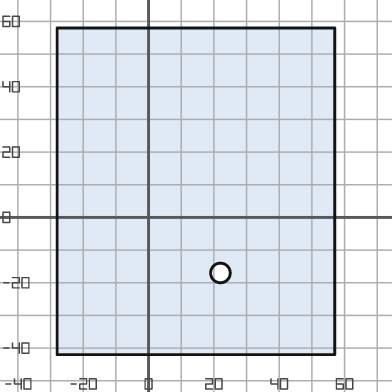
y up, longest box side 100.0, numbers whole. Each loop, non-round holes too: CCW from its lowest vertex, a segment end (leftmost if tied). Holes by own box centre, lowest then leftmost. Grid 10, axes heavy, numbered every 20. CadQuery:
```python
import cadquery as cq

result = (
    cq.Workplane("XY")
    .moveTo(-28.0, -42.0)
    .lineTo(57.0, -42.0)
    .lineTo(57.0, 58.0)
    .lineTo(-28.0, 58.0)
    .close()
    .moveTo(22.0, -17.0)
    .circle(3.0)
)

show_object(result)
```